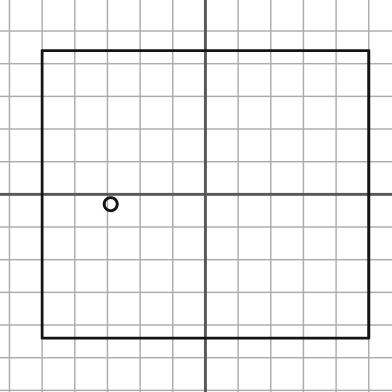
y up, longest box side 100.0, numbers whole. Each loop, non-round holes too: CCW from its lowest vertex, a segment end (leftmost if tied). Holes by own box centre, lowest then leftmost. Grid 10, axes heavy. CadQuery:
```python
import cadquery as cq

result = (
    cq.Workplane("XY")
    .moveTo(-50.0, -44.0)
    .lineTo(50.0, -44.0)
    .lineTo(50.0, 44.0)
    .lineTo(-50.0, 44.0)
    .close()
    .moveTo(-29.0, -3.0)
    .circle(2.0)
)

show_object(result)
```